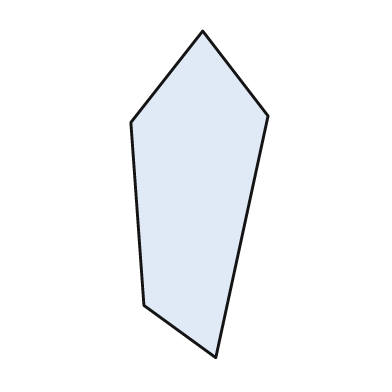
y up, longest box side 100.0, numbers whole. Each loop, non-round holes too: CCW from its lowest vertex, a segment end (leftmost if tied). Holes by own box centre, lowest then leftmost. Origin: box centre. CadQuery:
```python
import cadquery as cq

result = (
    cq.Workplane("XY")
    .moveTo(5.0, -50.0)
    .lineTo(21.0, 24.0)
    .lineTo(1.0, 50.0)
    .lineTo(-21.0, 22.0)
    .lineTo(-17.0, -34.0)
    .close()
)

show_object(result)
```